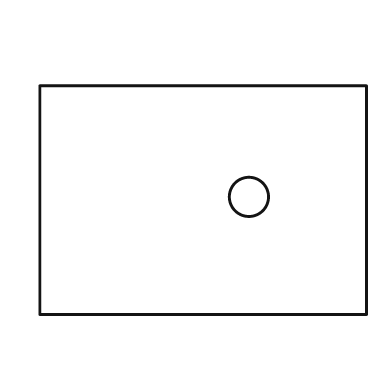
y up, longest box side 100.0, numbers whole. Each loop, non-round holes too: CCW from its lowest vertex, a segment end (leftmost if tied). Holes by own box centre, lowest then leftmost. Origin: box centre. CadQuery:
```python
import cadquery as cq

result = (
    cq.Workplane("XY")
    .moveTo(-50.0, -35.0)
    .lineTo(50.0, -35.0)
    .lineTo(50.0, 35.0)
    .lineTo(-50.0, 35.0)
    .close()
    .moveTo(14.0, 1.0)
    .circle(6.0)
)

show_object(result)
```